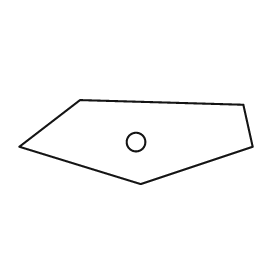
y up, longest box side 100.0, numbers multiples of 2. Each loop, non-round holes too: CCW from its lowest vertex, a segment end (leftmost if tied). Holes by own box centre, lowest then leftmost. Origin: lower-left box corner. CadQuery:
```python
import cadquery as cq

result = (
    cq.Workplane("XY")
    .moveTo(52.0, 0.0)
    .lineTo(100.0, 16.0)
    .lineTo(96.0, 34.0)
    .lineTo(26.0, 36.0)
    .lineTo(0.0, 16.0)
    .close()
    .moveTo(50.0, 18.0)
    .circle(4.0)
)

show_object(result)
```